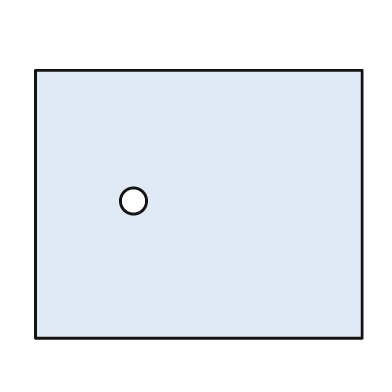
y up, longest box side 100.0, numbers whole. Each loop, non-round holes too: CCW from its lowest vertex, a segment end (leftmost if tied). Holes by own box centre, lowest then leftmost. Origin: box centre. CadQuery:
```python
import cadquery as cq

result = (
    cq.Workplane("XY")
    .moveTo(-50.0, -41.0)
    .lineTo(50.0, -41.0)
    .lineTo(50.0, 41.0)
    .lineTo(-50.0, 41.0)
    .close()
    .moveTo(-20.0, 1.0)
    .circle(4.0)
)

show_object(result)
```